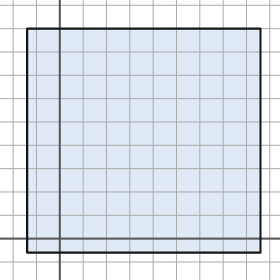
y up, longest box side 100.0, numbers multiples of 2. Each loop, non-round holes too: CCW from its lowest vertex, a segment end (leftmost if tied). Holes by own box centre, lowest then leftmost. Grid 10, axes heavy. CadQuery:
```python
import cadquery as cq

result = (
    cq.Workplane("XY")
    .moveTo(-14.0, -6.0)
    .lineTo(86.0, -6.0)
    .lineTo(86.0, 90.0)
    .lineTo(-14.0, 90.0)
    .close()
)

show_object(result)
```